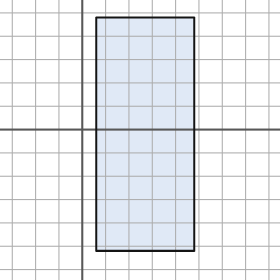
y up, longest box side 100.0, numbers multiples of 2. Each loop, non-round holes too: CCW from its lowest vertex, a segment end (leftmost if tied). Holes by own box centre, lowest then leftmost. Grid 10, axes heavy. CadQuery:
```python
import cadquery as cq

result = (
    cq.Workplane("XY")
    .moveTo(6.0, -52.0)
    .lineTo(48.0, -52.0)
    .lineTo(48.0, 48.0)
    .lineTo(6.0, 48.0)
    .close()
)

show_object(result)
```